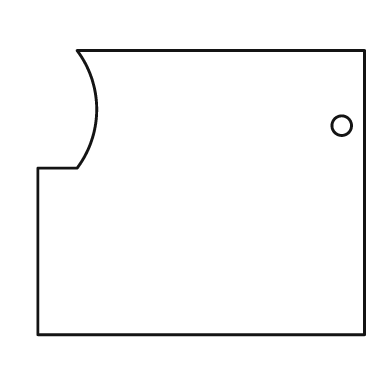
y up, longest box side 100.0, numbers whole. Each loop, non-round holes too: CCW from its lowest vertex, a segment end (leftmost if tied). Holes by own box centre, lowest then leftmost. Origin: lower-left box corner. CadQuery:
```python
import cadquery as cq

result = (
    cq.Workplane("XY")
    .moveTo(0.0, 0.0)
    .lineTo(100.0, 0.0)
    .lineTo(100.0, 87.0)
    .lineTo(12.0, 87.0)
    .threePointArc((18.0, 69.0), (12.0, 51.0))
    .lineTo(0.0, 51.0)
    .close()
    .moveTo(93.0, 64.0)
    .circle(3.0)
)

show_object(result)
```